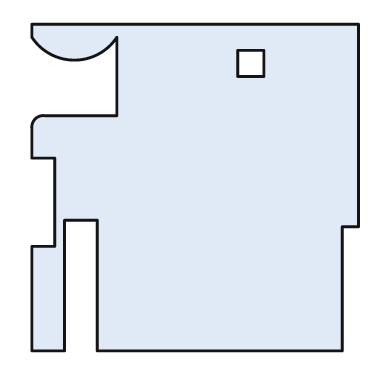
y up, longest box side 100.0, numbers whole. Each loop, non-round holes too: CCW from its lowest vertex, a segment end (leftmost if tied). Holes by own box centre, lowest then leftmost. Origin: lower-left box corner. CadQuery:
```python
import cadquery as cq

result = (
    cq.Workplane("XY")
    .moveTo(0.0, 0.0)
    .lineTo(10.0, 0.0)
    .lineTo(10.0, 40.0)
    .lineTo(20.0, 40.0)
    .lineTo(20.0, 0.0)
    .lineTo(95.0, 0.0)
    .lineTo(95.0, 38.0)
    .lineTo(100.0, 38.0)
    .lineTo(100.0, 100.0)
    .lineTo(0.0, 100.0)
    .lineTo(0.0, 96.0)
    .threePointArc((13.0, 89.0), (26.0, 96.0))
    .lineTo(26.0, 72.0)
    .lineTo(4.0, 72.0)
    .threePointArc((1.0, 71.0), (0.0, 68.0))
    .lineTo(0.0, 59.0)
    .lineTo(7.0, 59.0)
    .lineTo(7.0, 32.0)
    .lineTo(0.0, 32.0)
    .close()
    .moveTo(63.0, 84.0)
    .lineTo(71.0, 84.0)
    .lineTo(71.0, 92.0)
    .lineTo(63.0, 92.0)
    .close()
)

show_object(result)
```